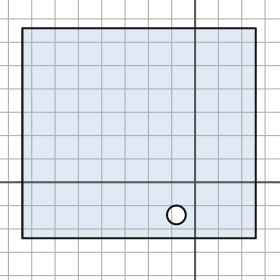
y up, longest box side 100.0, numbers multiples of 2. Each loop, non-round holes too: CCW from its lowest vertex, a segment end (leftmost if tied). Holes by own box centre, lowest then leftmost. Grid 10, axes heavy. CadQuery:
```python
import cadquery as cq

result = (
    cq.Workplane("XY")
    .moveTo(-74.0, -24.0)
    .lineTo(26.0, -24.0)
    .lineTo(26.0, 66.0)
    .lineTo(-74.0, 66.0)
    .close()
    .moveTo(-8.0, -14.0)
    .circle(4.0)
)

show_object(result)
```